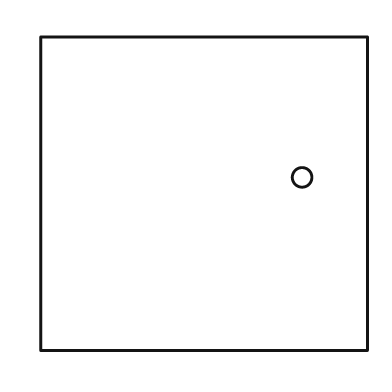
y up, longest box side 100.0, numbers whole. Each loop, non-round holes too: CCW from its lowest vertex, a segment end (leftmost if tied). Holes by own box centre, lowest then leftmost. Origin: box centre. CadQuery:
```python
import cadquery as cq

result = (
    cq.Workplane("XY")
    .moveTo(-50.0, -48.0)
    .lineTo(50.0, -48.0)
    .lineTo(50.0, 48.0)
    .lineTo(-50.0, 48.0)
    .close()
    .moveTo(30.0, 5.0)
    .circle(3.0)
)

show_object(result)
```